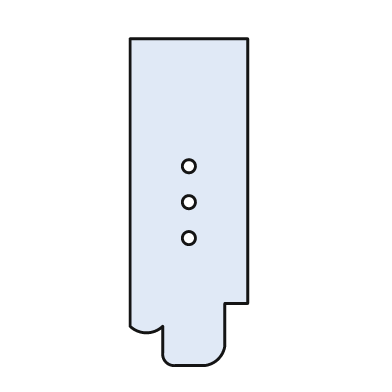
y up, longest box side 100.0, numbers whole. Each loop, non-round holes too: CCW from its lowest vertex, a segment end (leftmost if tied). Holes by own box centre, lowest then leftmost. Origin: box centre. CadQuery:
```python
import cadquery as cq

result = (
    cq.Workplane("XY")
    .moveTo(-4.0, -50.0)
    .lineTo(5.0, -50.0)
    .threePointArc((9.0, -48.0), (11.0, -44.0))
    .lineTo(11.0, -31.0)
    .lineTo(18.0, -31.0)
    .lineTo(18.0, 50.0)
    .lineTo(-18.0, 50.0)
    .lineTo(-18.0, -38.0)
    .threePointArc((-13.0, -40.0), (-8.0, -38.0))
    .lineTo(-8.0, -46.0)
    .threePointArc((-7.0, -49.0), (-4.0, -50.0))
    .close()
    .moveTo(0.0, -11.0)
    .circle(2.0)
    .moveTo(0.0, 0.0)
    .circle(2.0)
    .moveTo(0.0, 11.0)
    .circle(2.0)
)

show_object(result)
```